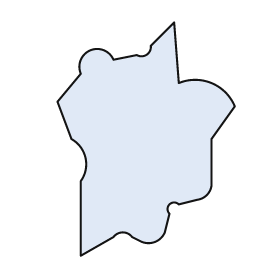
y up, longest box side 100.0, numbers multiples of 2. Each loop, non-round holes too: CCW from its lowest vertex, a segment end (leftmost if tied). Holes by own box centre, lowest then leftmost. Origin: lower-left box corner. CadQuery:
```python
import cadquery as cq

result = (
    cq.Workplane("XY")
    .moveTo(10.0, 0.0)
    .lineTo(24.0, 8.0)
    .threePointArc((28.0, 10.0), (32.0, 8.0))
    .lineTo(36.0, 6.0)
    .threePointArc((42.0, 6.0), (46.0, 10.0))
    .lineTo(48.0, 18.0)
    .threePointArc((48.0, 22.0), (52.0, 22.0))
    .lineTo(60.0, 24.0)
    .threePointArc((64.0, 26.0), (66.0, 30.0))
    .lineTo(66.0, 50.0)
    .lineTo(76.0, 64.0)
    .threePointArc((66.0, 74.0), (52.0, 74.0))
    .lineTo(50.0, 100.0)
    .lineTo(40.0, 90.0)
    .threePointArc((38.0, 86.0), (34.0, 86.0))
    .lineTo(24.0, 84.0)
    .threePointArc((14.0, 88.0), (10.0, 78.0))
    .lineTo(0.0, 66.0)
    .lineTo(6.0, 50.0)
    .threePointArc((12.0, 42.0), (10.0, 32.0))
    .close()
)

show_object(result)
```